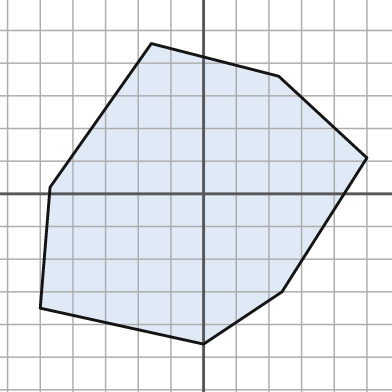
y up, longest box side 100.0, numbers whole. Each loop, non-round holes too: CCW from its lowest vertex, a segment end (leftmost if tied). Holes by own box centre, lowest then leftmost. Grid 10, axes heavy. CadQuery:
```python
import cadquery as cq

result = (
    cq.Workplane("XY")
    .moveTo(0.0, -46.0)
    .lineTo(24.0, -30.0)
    .lineTo(50.0, 11.0)
    .lineTo(23.0, 36.0)
    .lineTo(-16.0, 46.0)
    .lineTo(-47.0, 2.0)
    .lineTo(-50.0, -35.0)
    .close()
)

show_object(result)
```